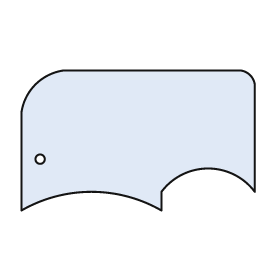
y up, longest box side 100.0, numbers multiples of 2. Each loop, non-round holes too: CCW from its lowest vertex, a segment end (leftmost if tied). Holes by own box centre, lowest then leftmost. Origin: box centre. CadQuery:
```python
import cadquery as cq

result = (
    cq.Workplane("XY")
    .moveTo(-50.0, -30.0)
    .threePointArc((-20.0, -22.0), (10.0, -30.0))
    .lineTo(10.0, -22.0)
    .threePointArc((30.0, -12.0), (50.0, -22.0))
    .lineTo(50.0, 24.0)
    .threePointArc((48.0, 28.0), (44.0, 30.0))
    .lineTo(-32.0, 30.0)
    .threePointArc((-44.0, 24.0), (-50.0, 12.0))
    .close()
    .moveTo(-42.0, -8.0)
    .circle(2.0)
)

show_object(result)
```